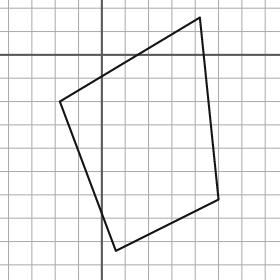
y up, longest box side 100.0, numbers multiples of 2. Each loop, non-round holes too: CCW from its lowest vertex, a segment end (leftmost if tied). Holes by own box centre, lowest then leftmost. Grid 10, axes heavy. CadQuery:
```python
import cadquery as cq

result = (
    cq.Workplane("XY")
    .moveTo(6.0, -84.0)
    .lineTo(50.0, -62.0)
    .lineTo(42.0, 16.0)
    .lineTo(-18.0, -20.0)
    .close()
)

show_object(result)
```